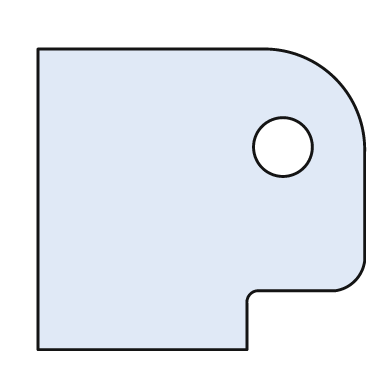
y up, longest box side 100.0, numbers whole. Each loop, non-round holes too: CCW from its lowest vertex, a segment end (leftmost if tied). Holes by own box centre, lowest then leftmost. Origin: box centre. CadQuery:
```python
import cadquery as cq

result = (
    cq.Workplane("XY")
    .moveTo(-50.0, -46.0)
    .lineTo(14.0, -46.0)
    .lineTo(14.0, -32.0)
    .threePointArc((15.0, -29.0), (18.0, -28.0))
    .lineTo(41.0, -28.0)
    .threePointArc((47.0, -25.0), (50.0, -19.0))
    .lineTo(50.0, 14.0)
    .threePointArc((41.0, 37.0), (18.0, 46.0))
    .lineTo(-50.0, 46.0)
    .close()
    .moveTo(25.0, 16.0)
    .circle(9.0)
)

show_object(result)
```